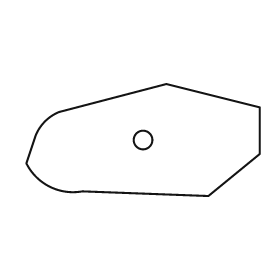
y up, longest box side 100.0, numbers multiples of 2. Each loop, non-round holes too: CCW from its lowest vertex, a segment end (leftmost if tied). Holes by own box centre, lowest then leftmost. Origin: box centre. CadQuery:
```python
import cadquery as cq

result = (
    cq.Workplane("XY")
    .moveTo(28.0, -24.0)
    .lineTo(50.0, -6.0)
    .lineTo(50.0, 14.0)
    .lineTo(10.0, 24.0)
    .lineTo(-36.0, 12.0)
    .threePointArc((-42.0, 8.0), (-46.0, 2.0))
    .lineTo(-50.0, -10.0)
    .threePointArc((-40.0, -20.0), (-26.0, -22.0))
    .close()
    .moveTo(0.0, 0.0)
    .circle(4.0)
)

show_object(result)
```